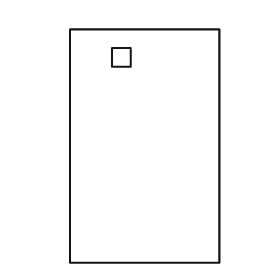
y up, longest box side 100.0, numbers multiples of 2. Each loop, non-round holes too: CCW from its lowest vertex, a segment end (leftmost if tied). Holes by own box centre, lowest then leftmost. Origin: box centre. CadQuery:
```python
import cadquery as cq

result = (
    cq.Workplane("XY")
    .moveTo(-32.0, -50.0)
    .lineTo(32.0, -50.0)
    .lineTo(32.0, 50.0)
    .lineTo(-32.0, 50.0)
    .close()
    .moveTo(-14.0, 34.0)
    .lineTo(-6.0, 34.0)
    .lineTo(-6.0, 42.0)
    .lineTo(-14.0, 42.0)
    .close()
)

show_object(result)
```